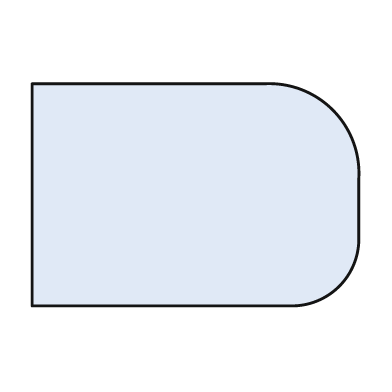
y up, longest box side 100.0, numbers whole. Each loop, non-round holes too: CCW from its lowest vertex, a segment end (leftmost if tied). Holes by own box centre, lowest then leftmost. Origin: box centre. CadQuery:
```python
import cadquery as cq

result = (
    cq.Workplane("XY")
    .moveTo(-50.0, -34.0)
    .lineTo(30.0, -34.0)
    .threePointArc((44.0, -28.0), (50.0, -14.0))
    .lineTo(50.0, 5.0)
    .threePointArc((42.0, 26.0), (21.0, 34.0))
    .lineTo(-50.0, 34.0)
    .close()
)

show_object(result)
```